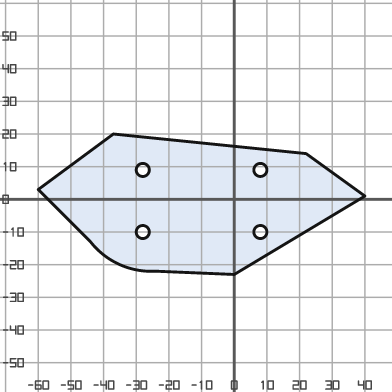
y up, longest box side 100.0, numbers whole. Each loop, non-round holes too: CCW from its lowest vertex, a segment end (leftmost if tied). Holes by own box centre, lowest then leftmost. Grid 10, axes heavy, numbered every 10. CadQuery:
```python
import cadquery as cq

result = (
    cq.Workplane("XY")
    .moveTo(0.0, -23.0)
    .lineTo(40.0, 1.0)
    .lineTo(22.0, 14.0)
    .lineTo(-37.0, 20.0)
    .lineTo(-60.0, 3.0)
    .lineTo(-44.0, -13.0)
    .threePointArc((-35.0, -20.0), (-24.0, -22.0))
    .close()
    .moveTo(-28.0, -10.0)
    .circle(2.0)
    .moveTo(8.0, -10.0)
    .circle(2.0)
    .moveTo(-28.0, 9.0)
    .circle(2.0)
    .moveTo(8.0, 9.0)
    .circle(2.0)
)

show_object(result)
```